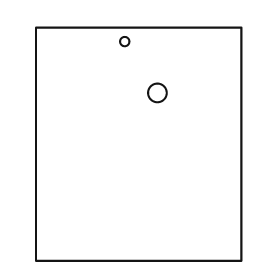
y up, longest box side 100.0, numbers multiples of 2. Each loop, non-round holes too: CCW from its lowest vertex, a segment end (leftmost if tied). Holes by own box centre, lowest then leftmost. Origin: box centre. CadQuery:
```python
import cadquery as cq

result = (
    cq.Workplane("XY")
    .moveTo(-44.0, -50.0)
    .lineTo(44.0, -50.0)
    .lineTo(44.0, 50.0)
    .lineTo(-44.0, 50.0)
    .close()
    .moveTo(8.0, 22.0)
    .circle(4.0)
    .moveTo(-6.0, 44.0)
    .circle(2.0)
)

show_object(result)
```